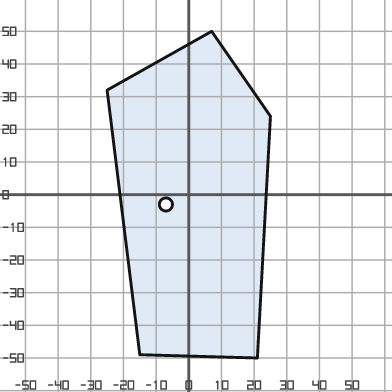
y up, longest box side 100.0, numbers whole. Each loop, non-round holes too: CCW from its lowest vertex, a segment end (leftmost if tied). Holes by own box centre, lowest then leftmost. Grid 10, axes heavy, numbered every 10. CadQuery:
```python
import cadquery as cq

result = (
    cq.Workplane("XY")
    .moveTo(21.0, -50.0)
    .lineTo(25.0, 24.0)
    .lineTo(7.0, 50.0)
    .lineTo(-25.0, 32.0)
    .lineTo(-15.0, -49.0)
    .close()
    .moveTo(-7.0, -3.0)
    .circle(2.0)
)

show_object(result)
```